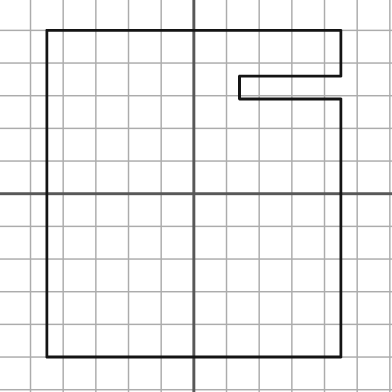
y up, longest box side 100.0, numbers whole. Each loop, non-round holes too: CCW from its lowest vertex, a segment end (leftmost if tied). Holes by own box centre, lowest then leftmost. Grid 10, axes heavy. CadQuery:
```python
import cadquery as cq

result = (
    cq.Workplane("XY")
    .moveTo(-45.0, -50.0)
    .lineTo(45.0, -50.0)
    .lineTo(45.0, 29.0)
    .lineTo(14.0, 29.0)
    .lineTo(14.0, 36.0)
    .lineTo(45.0, 36.0)
    .lineTo(45.0, 50.0)
    .lineTo(-45.0, 50.0)
    .close()
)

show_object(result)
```